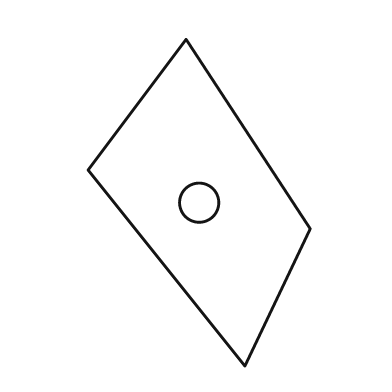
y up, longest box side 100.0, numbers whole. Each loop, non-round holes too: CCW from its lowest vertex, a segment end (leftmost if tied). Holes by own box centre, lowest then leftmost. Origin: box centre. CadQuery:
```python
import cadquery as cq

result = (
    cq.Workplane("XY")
    .moveTo(14.0, -50.0)
    .lineTo(34.0, -8.0)
    .lineTo(-4.0, 50.0)
    .lineTo(-34.0, 10.0)
    .close()
    .moveTo(0.0, 0.0)
    .circle(6.0)
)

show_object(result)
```